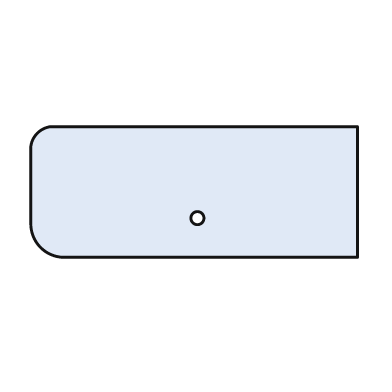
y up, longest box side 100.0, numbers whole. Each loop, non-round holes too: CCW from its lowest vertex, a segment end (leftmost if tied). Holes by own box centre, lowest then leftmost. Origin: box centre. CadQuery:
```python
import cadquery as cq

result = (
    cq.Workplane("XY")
    .moveTo(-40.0, -20.0)
    .lineTo(50.0, -20.0)
    .lineTo(50.0, 20.0)
    .lineTo(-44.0, 20.0)
    .threePointArc((-48.0, 18.0), (-50.0, 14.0))
    .lineTo(-50.0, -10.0)
    .threePointArc((-47.0, -17.0), (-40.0, -20.0))
    .close()
    .moveTo(1.0, -8.0)
    .circle(2.0)
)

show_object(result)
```